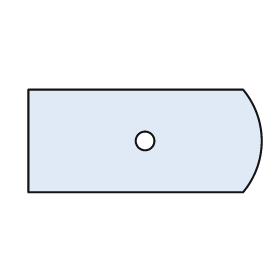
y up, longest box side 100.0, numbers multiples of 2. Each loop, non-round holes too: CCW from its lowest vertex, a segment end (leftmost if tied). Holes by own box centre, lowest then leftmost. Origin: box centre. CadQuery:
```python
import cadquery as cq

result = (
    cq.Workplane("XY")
    .moveTo(-50.0, -22.0)
    .lineTo(42.0, -22.0)
    .threePointArc((50.0, 0.0), (42.0, 22.0))
    .lineTo(-50.0, 22.0)
    .close()
    .moveTo(0.0, 0.0)
    .circle(4.0)
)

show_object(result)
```